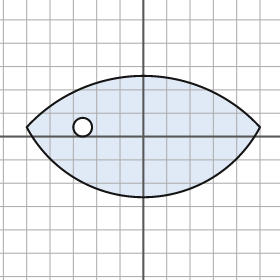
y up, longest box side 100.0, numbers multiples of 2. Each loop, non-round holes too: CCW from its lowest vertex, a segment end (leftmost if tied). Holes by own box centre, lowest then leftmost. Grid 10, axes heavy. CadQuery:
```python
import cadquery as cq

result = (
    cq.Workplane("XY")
    .moveTo(-50.0, 4.0)
    .threePointArc((0.0, -26.0), (50.0, 4.0))
    .threePointArc((0.0, 26.0), (-50.0, 4.0))
    .close()
    .moveTo(-26.0, 4.0)
    .circle(4.0)
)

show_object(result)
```